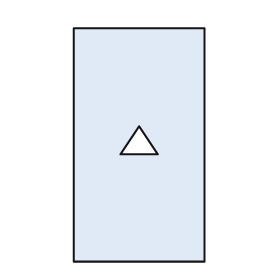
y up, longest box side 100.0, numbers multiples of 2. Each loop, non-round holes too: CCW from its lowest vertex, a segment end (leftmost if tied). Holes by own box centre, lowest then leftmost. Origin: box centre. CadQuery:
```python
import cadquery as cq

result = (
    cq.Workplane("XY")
    .moveTo(-28.0, -50.0)
    .lineTo(28.0, -50.0)
    .lineTo(28.0, 50.0)
    .lineTo(-28.0, 50.0)
    .close()
    .moveTo(-8.0, -4.0)
    .lineTo(8.0, -4.0)
    .lineTo(0.0, 8.0)
    .close()
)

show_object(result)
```